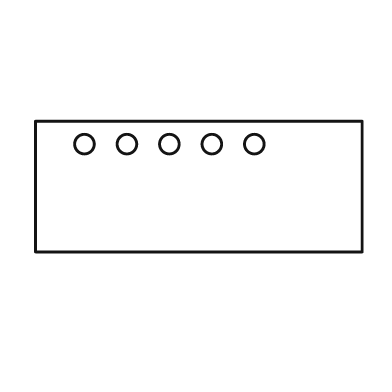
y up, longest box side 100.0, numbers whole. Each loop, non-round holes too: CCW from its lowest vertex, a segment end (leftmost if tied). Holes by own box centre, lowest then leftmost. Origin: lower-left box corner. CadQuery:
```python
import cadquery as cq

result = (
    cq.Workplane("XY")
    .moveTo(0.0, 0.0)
    .lineTo(100.0, 0.0)
    .lineTo(100.0, 40.0)
    .lineTo(0.0, 40.0)
    .close()
    .moveTo(15.0, 33.0)
    .circle(3.0)
    .moveTo(28.0, 33.0)
    .circle(3.0)
    .moveTo(41.0, 33.0)
    .circle(3.0)
    .moveTo(54.0, 33.0)
    .circle(3.0)
    .moveTo(67.0, 33.0)
    .circle(3.0)
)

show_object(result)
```